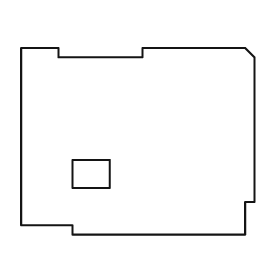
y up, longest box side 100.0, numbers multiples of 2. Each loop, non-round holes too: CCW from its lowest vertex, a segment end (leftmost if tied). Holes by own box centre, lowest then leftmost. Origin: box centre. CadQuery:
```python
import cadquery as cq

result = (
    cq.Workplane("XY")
    .moveTo(-28.0, -40.0)
    .lineTo(46.0, -40.0)
    .lineTo(46.0, -26.0)
    .lineTo(50.0, -26.0)
    .lineTo(50.0, 36.0)
    .lineTo(46.0, 40.0)
    .lineTo(2.0, 40.0)
    .lineTo(2.0, 36.0)
    .lineTo(-34.0, 36.0)
    .lineTo(-34.0, 40.0)
    .lineTo(-50.0, 40.0)
    .lineTo(-50.0, -36.0)
    .lineTo(-28.0, -36.0)
    .close()
    .moveTo(-28.0, -20.0)
    .lineTo(-12.0, -20.0)
    .lineTo(-12.0, -8.0)
    .lineTo(-28.0, -8.0)
    .close()
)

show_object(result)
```